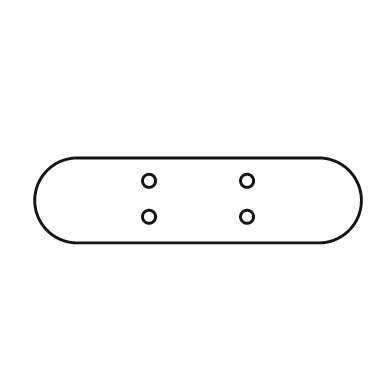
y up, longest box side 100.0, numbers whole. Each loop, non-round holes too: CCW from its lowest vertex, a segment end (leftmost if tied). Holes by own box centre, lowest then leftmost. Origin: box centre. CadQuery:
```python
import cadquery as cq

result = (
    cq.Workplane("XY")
    .moveTo(-37.0, -13.0)
    .lineTo(37.0, -13.0)
    .threePointArc((50.0, 0.0), (37.0, 13.0))
    .lineTo(-37.0, 13.0)
    .threePointArc((-50.0, 0.0), (-37.0, -13.0))
    .close()
    .moveTo(-15.0, -5.0)
    .circle(2.0)
    .moveTo(15.0, -5.0)
    .circle(2.0)
    .moveTo(-15.0, 6.0)
    .circle(2.0)
    .moveTo(15.0, 6.0)
    .circle(2.0)
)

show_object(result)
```